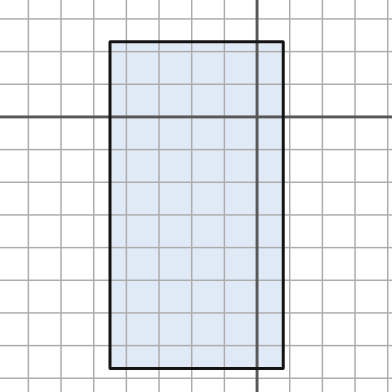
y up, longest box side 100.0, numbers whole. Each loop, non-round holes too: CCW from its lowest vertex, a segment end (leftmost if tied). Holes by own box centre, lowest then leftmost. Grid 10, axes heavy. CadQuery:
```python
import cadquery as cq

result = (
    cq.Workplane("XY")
    .moveTo(-45.0, -77.0)
    .lineTo(8.0, -77.0)
    .lineTo(8.0, 23.0)
    .lineTo(-45.0, 23.0)
    .close()
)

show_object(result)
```